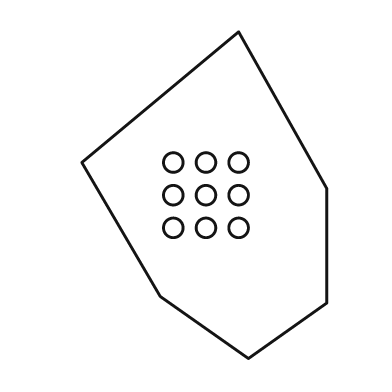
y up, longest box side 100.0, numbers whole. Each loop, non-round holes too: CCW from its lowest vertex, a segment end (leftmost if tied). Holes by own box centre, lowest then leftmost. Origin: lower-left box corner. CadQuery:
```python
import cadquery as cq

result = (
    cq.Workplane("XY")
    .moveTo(51.0, 0.0)
    .lineTo(75.0, 17.0)
    .lineTo(75.0, 52.0)
    .lineTo(48.0, 100.0)
    .lineTo(0.0, 60.0)
    .lineTo(24.0, 19.0)
    .close()
    .moveTo(28.0, 40.0)
    .circle(3.0)
    .moveTo(38.0, 40.0)
    .circle(3.0)
    .moveTo(48.0, 40.0)
    .circle(3.0)
    .moveTo(28.0, 50.0)
    .circle(3.0)
    .moveTo(38.0, 50.0)
    .circle(3.0)
    .moveTo(48.0, 50.0)
    .circle(3.0)
    .moveTo(28.0, 60.0)
    .circle(3.0)
    .moveTo(38.0, 60.0)
    .circle(3.0)
    .moveTo(48.0, 60.0)
    .circle(3.0)
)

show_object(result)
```